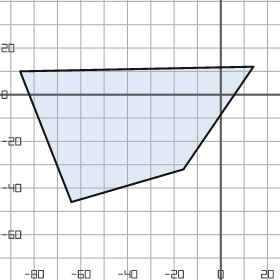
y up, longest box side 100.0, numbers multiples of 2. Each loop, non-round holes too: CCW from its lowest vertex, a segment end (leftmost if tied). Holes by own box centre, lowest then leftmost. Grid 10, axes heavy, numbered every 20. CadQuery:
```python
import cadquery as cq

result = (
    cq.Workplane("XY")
    .moveTo(-64.0, -46.0)
    .lineTo(-16.0, -32.0)
    .lineTo(14.0, 12.0)
    .lineTo(-86.0, 10.0)
    .close()
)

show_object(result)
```